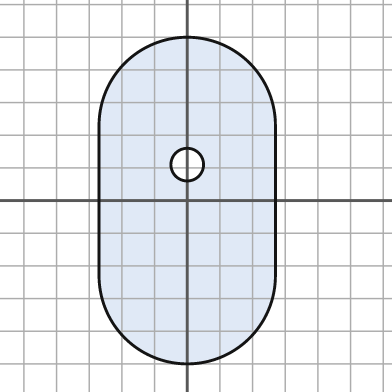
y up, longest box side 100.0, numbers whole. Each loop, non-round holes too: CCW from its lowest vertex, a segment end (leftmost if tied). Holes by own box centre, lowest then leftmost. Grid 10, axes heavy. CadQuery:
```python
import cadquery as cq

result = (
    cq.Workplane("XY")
    .moveTo(-27.0, -23.0)
    .threePointArc((0.0, -50.0), (27.0, -23.0))
    .lineTo(27.0, 23.0)
    .threePointArc((0.0, 50.0), (-27.0, 23.0))
    .close()
    .moveTo(0.0, 11.0)
    .circle(5.0)
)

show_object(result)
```